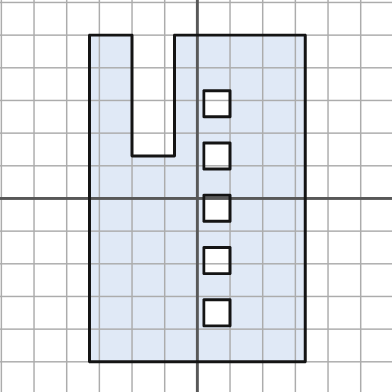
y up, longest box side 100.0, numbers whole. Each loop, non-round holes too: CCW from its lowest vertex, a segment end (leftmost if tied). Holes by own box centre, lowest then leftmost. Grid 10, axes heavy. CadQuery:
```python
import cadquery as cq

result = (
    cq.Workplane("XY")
    .moveTo(-33.0, -50.0)
    .lineTo(33.0, -50.0)
    .lineTo(33.0, 50.0)
    .lineTo(-7.0, 50.0)
    .lineTo(-7.0, 13.0)
    .lineTo(-20.0, 13.0)
    .lineTo(-20.0, 50.0)
    .lineTo(-33.0, 50.0)
    .close()
    .moveTo(2.0, -39.0)
    .lineTo(10.0, -39.0)
    .lineTo(10.0, -31.0)
    .lineTo(2.0, -31.0)
    .close()
    .moveTo(2.0, -23.0)
    .lineTo(10.0, -23.0)
    .lineTo(10.0, -15.0)
    .lineTo(2.0, -15.0)
    .close()
    .moveTo(2.0, -7.0)
    .lineTo(10.0, -7.0)
    .lineTo(10.0, 1.0)
    .lineTo(2.0, 1.0)
    .close()
    .moveTo(2.0, 9.0)
    .lineTo(10.0, 9.0)
    .lineTo(10.0, 17.0)
    .lineTo(2.0, 17.0)
    .close()
    .moveTo(2.0, 25.0)
    .lineTo(10.0, 25.0)
    .lineTo(10.0, 33.0)
    .lineTo(2.0, 33.0)
    .close()
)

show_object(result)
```